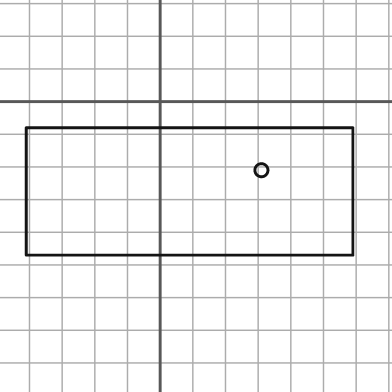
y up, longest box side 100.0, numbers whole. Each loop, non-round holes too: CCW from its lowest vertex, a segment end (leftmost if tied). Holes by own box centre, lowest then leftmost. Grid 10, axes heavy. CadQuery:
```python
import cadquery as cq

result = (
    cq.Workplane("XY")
    .moveTo(-41.0, -47.0)
    .lineTo(59.0, -47.0)
    .lineTo(59.0, -8.0)
    .lineTo(-41.0, -8.0)
    .close()
    .moveTo(31.0, -21.0)
    .circle(2.0)
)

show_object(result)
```